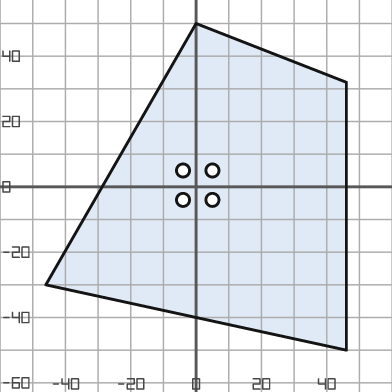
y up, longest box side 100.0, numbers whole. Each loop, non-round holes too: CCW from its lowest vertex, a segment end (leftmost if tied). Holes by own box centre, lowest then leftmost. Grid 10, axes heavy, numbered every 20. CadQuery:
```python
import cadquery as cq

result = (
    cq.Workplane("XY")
    .moveTo(46.0, -50.0)
    .lineTo(46.0, 32.0)
    .lineTo(0.0, 50.0)
    .lineTo(-46.0, -30.0)
    .close()
    .moveTo(-4.0, -4.0)
    .circle(2.0)
    .moveTo(5.0, -4.0)
    .circle(2.0)
    .moveTo(-4.0, 5.0)
    .circle(2.0)
    .moveTo(5.0, 5.0)
    .circle(2.0)
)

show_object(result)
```